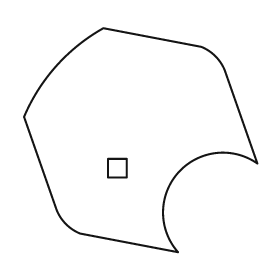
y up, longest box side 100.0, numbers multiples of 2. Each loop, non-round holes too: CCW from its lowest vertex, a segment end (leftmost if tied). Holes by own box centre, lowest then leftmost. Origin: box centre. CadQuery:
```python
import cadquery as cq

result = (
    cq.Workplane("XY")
    .moveTo(16.0, -48.0)
    .threePointArc((16.0, -14.0), (50.0, -10.0))
    .lineTo(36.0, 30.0)
    .threePointArc((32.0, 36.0), (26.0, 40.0))
    .lineTo(-16.0, 48.0)
    .threePointArc((-36.0, 32.0), (-50.0, 10.0))
    .lineTo(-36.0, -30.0)
    .threePointArc((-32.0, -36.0), (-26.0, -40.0))
    .close()
    .moveTo(-14.0, -16.0)
    .lineTo(-6.0, -16.0)
    .lineTo(-6.0, -8.0)
    .lineTo(-14.0, -8.0)
    .close()
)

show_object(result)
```